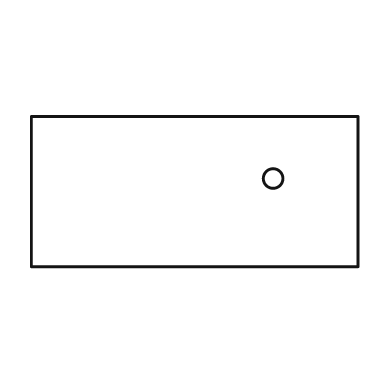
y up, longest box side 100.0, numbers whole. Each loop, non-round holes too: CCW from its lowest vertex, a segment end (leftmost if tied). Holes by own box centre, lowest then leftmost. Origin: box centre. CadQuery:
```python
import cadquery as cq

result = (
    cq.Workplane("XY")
    .moveTo(-50.0, -23.0)
    .lineTo(50.0, -23.0)
    .lineTo(50.0, 23.0)
    .lineTo(-50.0, 23.0)
    .close()
    .moveTo(24.0, 4.0)
    .circle(3.0)
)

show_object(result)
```